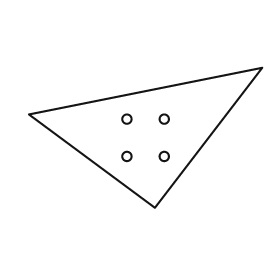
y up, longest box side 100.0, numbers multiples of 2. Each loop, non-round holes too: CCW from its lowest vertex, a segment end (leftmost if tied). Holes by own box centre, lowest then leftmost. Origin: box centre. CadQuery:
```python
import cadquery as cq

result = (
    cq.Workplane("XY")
    .moveTo(4.0, -30.0)
    .lineTo(50.0, 30.0)
    .lineTo(-50.0, 10.0)
    .close()
    .moveTo(-8.0, -8.0)
    .circle(2.0)
    .moveTo(8.0, -8.0)
    .circle(2.0)
    .moveTo(-8.0, 8.0)
    .circle(2.0)
    .moveTo(8.0, 8.0)
    .circle(2.0)
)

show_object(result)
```